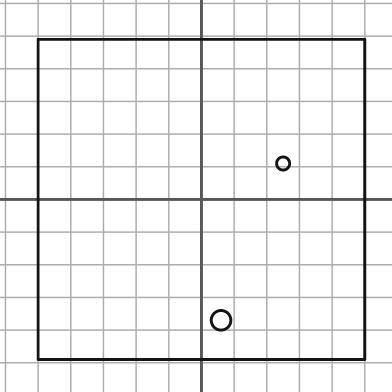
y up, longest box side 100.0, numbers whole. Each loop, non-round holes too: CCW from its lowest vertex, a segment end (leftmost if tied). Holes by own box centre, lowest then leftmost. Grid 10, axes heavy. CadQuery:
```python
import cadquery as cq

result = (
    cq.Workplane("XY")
    .moveTo(-50.0, -49.0)
    .lineTo(50.0, -49.0)
    .lineTo(50.0, 49.0)
    .lineTo(-50.0, 49.0)
    .close()
    .moveTo(6.0, -37.0)
    .circle(3.0)
    .moveTo(25.0, 11.0)
    .circle(2.0)
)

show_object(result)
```